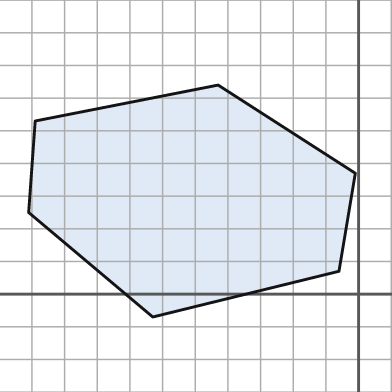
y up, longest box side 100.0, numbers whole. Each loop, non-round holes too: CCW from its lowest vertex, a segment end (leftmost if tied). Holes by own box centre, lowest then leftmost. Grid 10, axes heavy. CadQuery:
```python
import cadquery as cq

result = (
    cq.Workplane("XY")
    .moveTo(-63.0, -7.0)
    .lineTo(-6.0, 7.0)
    .lineTo(-1.0, 37.0)
    .lineTo(-43.0, 64.0)
    .lineTo(-99.0, 53.0)
    .lineTo(-101.0, 25.0)
    .close()
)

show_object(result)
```